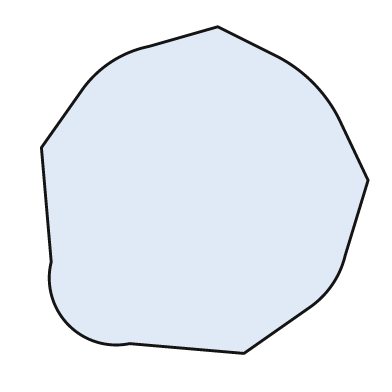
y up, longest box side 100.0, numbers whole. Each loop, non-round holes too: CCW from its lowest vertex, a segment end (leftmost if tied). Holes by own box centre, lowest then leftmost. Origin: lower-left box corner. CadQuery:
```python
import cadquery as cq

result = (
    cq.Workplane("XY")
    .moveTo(62.0, 0.0)
    .lineTo(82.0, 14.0)
    .threePointArc((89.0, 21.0), (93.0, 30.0))
    .lineTo(100.0, 53.0)
    .lineTo(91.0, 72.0)
    .threePointArc((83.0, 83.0), (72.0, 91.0))
    .lineTo(54.0, 100.0)
    .lineTo(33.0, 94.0)
    .threePointArc((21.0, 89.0), (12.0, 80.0))
    .lineTo(0.0, 63.0)
    .lineTo(3.0, 28.0)
    .threePointArc((8.0, 9.0), (27.0, 3.0))
    .close()
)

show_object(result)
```